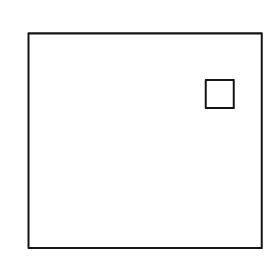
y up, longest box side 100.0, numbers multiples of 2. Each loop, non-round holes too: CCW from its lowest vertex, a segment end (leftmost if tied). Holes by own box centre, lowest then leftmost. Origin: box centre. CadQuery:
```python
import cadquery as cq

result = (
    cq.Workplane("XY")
    .moveTo(-50.0, -46.0)
    .lineTo(50.0, -46.0)
    .lineTo(50.0, 46.0)
    .lineTo(-50.0, 46.0)
    .close()
    .moveTo(26.0, 14.0)
    .lineTo(38.0, 14.0)
    .lineTo(38.0, 26.0)
    .lineTo(26.0, 26.0)
    .close()
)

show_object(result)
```